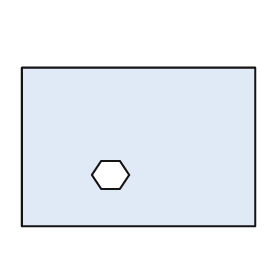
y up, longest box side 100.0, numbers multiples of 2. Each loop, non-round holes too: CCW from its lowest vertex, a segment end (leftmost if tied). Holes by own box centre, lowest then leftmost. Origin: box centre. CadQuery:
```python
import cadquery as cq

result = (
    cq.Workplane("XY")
    .moveTo(-50.0, -34.0)
    .lineTo(50.0, -34.0)
    .lineTo(50.0, 34.0)
    .lineTo(-50.0, 34.0)
    .close()
    .moveTo(-16.0, -18.0)
    .lineTo(-8.0, -18.0)
    .lineTo(-4.0, -12.0)
    .lineTo(-8.0, -6.0)
    .lineTo(-16.0, -6.0)
    .lineTo(-20.0, -12.0)
    .close()
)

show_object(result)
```